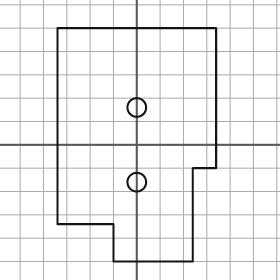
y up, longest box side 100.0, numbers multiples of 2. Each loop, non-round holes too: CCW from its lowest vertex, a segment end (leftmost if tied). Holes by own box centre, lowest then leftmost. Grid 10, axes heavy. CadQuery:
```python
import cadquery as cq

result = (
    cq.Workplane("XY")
    .moveTo(-10.0, -50.0)
    .lineTo(24.0, -50.0)
    .lineTo(24.0, -10.0)
    .lineTo(34.0, -10.0)
    .lineTo(34.0, 50.0)
    .lineTo(-34.0, 50.0)
    .lineTo(-34.0, -34.0)
    .lineTo(-10.0, -34.0)
    .close()
    .moveTo(0.0, -16.0)
    .circle(4.0)
    .moveTo(0.0, 16.0)
    .circle(4.0)
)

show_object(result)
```